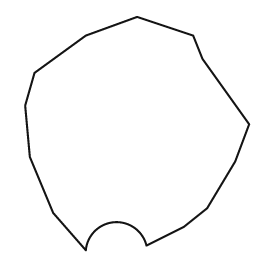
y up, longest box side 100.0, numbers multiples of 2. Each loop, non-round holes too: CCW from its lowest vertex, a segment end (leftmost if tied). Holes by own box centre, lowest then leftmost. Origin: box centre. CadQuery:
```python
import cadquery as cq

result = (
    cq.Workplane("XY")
    .moveTo(-22.0, -50.0)
    .threePointArc((-10.0, -38.0), (4.0, -48.0))
    .lineTo(20.0, -40.0)
    .lineTo(30.0, -32.0)
    .lineTo(42.0, -12.0)
    .lineTo(48.0, 4.0)
    .lineTo(28.0, 32.0)
    .lineTo(24.0, 42.0)
    .lineTo(0.0, 50.0)
    .lineTo(-22.0, 42.0)
    .lineTo(-44.0, 26.0)
    .lineTo(-48.0, 12.0)
    .lineTo(-46.0, -10.0)
    .lineTo(-36.0, -34.0)
    .close()
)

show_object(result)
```